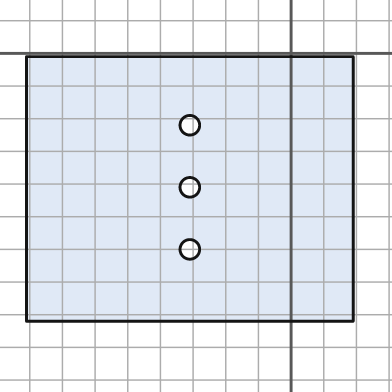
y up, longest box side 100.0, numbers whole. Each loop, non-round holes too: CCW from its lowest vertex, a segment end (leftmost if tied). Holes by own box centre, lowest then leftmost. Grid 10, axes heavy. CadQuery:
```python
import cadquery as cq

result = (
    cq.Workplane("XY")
    .moveTo(-81.0, -82.0)
    .lineTo(19.0, -82.0)
    .lineTo(19.0, -1.0)
    .lineTo(-81.0, -1.0)
    .close()
    .moveTo(-31.0, -60.0)
    .circle(3.0)
    .moveTo(-31.0, -41.0)
    .circle(3.0)
    .moveTo(-31.0, -22.0)
    .circle(3.0)
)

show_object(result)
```